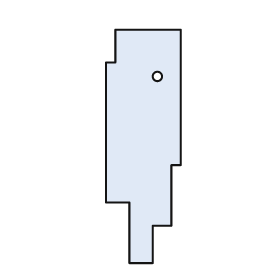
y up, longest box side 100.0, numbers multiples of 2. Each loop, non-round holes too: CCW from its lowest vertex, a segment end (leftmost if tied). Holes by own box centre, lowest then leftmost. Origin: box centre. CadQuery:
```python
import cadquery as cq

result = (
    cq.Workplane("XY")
    .moveTo(-6.0, -50.0)
    .lineTo(4.0, -50.0)
    .lineTo(4.0, -34.0)
    .lineTo(12.0, -34.0)
    .lineTo(12.0, -8.0)
    .lineTo(16.0, -8.0)
    .lineTo(16.0, 50.0)
    .lineTo(-12.0, 50.0)
    .lineTo(-12.0, 36.0)
    .lineTo(-16.0, 36.0)
    .lineTo(-16.0, -24.0)
    .lineTo(-6.0, -24.0)
    .close()
    .moveTo(6.0, 30.0)
    .circle(2.0)
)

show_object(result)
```